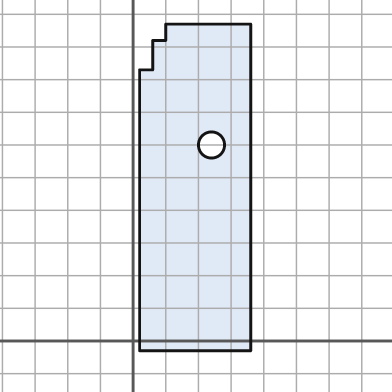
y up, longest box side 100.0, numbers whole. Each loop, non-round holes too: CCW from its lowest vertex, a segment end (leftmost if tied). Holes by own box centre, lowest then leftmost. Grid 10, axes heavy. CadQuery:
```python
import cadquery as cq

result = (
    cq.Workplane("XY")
    .moveTo(2.0, -3.0)
    .lineTo(36.0, -3.0)
    .lineTo(36.0, 97.0)
    .lineTo(10.0, 97.0)
    .lineTo(10.0, 92.0)
    .lineTo(6.0, 92.0)
    .lineTo(6.0, 83.0)
    .lineTo(2.0, 83.0)
    .close()
    .moveTo(24.0, 60.0)
    .circle(4.0)
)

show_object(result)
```